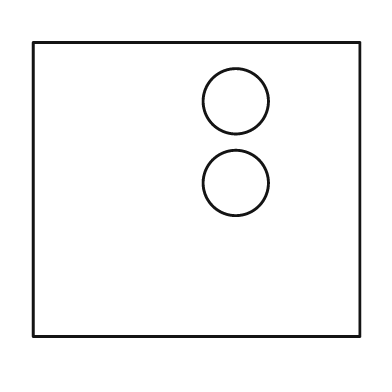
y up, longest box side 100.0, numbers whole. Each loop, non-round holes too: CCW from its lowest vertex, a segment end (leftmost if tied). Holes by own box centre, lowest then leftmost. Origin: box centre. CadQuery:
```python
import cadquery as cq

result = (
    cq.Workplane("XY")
    .moveTo(-50.0, -45.0)
    .lineTo(50.0, -45.0)
    .lineTo(50.0, 45.0)
    .lineTo(-50.0, 45.0)
    .close()
    .moveTo(12.0, 2.0)
    .circle(10.0)
    .moveTo(12.0, 27.0)
    .circle(10.0)
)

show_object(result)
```